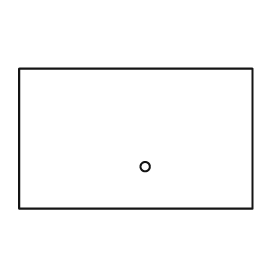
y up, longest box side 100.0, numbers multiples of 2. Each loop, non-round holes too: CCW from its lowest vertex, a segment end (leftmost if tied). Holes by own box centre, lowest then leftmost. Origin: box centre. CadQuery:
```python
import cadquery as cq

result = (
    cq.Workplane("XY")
    .moveTo(-50.0, -30.0)
    .lineTo(50.0, -30.0)
    .lineTo(50.0, 30.0)
    .lineTo(-50.0, 30.0)
    .close()
    .moveTo(4.0, -12.0)
    .circle(2.0)
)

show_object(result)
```